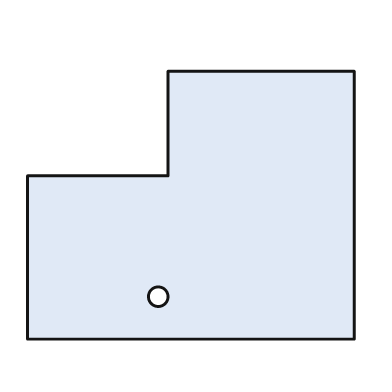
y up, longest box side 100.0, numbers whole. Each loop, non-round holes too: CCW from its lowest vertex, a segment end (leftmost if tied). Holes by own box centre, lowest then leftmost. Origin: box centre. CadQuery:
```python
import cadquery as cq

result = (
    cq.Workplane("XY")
    .moveTo(-50.0, -41.0)
    .lineTo(50.0, -41.0)
    .lineTo(50.0, 41.0)
    .lineTo(-7.0, 41.0)
    .lineTo(-7.0, 9.0)
    .lineTo(-50.0, 9.0)
    .close()
    .moveTo(-10.0, -28.0)
    .circle(3.0)
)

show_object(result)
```